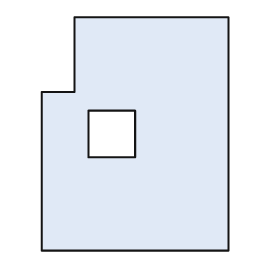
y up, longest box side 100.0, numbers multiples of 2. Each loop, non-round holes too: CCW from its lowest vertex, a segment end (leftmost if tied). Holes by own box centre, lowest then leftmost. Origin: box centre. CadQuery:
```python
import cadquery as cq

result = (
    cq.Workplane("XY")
    .moveTo(-40.0, -50.0)
    .lineTo(40.0, -50.0)
    .lineTo(40.0, 50.0)
    .lineTo(-26.0, 50.0)
    .lineTo(-26.0, 18.0)
    .lineTo(-40.0, 18.0)
    .close()
    .moveTo(-20.0, -10.0)
    .lineTo(0.0, -10.0)
    .lineTo(0.0, 10.0)
    .lineTo(-20.0, 10.0)
    .close()
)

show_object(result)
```